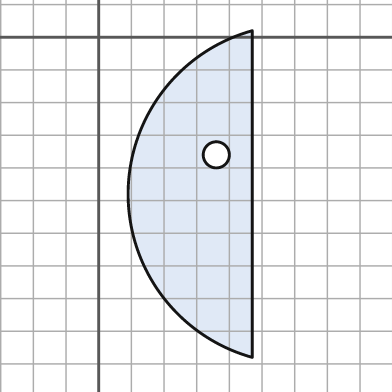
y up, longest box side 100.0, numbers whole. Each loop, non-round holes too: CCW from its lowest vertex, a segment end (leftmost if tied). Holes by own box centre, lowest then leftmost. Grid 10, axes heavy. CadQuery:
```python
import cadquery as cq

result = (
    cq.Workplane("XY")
    .moveTo(47.0, -98.0)
    .lineTo(47.0, 2.0)
    .threePointArc((9.0, -48.0), (47.0, -98.0))
    .close()
    .moveTo(36.0, -36.0)
    .circle(4.0)
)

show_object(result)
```